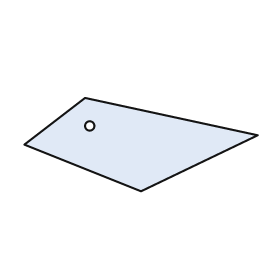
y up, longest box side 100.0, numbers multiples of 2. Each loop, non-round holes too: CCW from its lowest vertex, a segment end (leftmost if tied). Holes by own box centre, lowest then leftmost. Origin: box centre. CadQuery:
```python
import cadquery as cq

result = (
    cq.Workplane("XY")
    .moveTo(0.0, -20.0)
    .lineTo(50.0, 4.0)
    .lineTo(-24.0, 20.0)
    .lineTo(-50.0, 0.0)
    .close()
    .moveTo(-22.0, 8.0)
    .circle(2.0)
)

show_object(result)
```